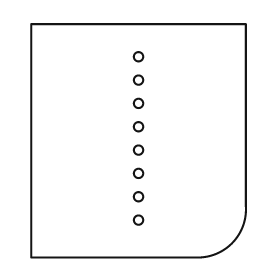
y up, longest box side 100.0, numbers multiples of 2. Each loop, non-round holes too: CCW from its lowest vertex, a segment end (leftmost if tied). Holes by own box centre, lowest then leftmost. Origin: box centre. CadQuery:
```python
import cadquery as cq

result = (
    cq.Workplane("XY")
    .moveTo(-46.0, -50.0)
    .lineTo(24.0, -50.0)
    .threePointArc((40.0, -44.0), (46.0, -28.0))
    .lineTo(46.0, 50.0)
    .lineTo(-46.0, 50.0)
    .close()
    .moveTo(0.0, -34.0)
    .circle(2.0)
    .moveTo(0.0, -24.0)
    .circle(2.0)
    .moveTo(0.0, -14.0)
    .circle(2.0)
    .moveTo(0.0, -4.0)
    .circle(2.0)
    .moveTo(0.0, 6.0)
    .circle(2.0)
    .moveTo(0.0, 16.0)
    .circle(2.0)
    .moveTo(0.0, 26.0)
    .circle(2.0)
    .moveTo(0.0, 36.0)
    .circle(2.0)
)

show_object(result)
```